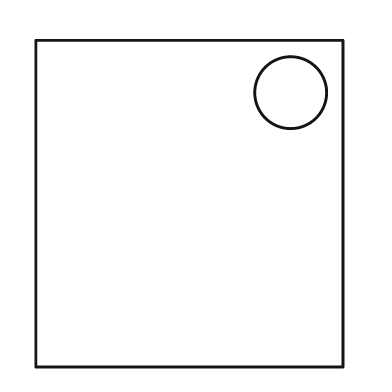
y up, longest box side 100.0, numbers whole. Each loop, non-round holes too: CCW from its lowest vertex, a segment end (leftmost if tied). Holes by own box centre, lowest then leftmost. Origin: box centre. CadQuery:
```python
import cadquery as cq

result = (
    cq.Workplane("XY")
    .moveTo(-47.0, -50.0)
    .lineTo(47.0, -50.0)
    .lineTo(47.0, 50.0)
    .lineTo(-47.0, 50.0)
    .close()
    .moveTo(31.0, 34.0)
    .circle(11.0)
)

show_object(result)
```